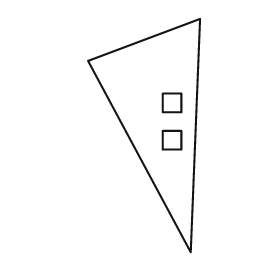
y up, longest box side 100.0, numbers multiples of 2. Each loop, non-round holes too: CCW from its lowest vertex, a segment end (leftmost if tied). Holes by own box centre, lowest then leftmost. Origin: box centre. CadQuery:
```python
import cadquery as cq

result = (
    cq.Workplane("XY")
    .moveTo(20.0, -50.0)
    .lineTo(24.0, 50.0)
    .lineTo(-24.0, 32.0)
    .close()
    .moveTo(8.0, -6.0)
    .lineTo(16.0, -6.0)
    .lineTo(16.0, 2.0)
    .lineTo(8.0, 2.0)
    .close()
    .moveTo(8.0, 10.0)
    .lineTo(16.0, 10.0)
    .lineTo(16.0, 18.0)
    .lineTo(8.0, 18.0)
    .close()
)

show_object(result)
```